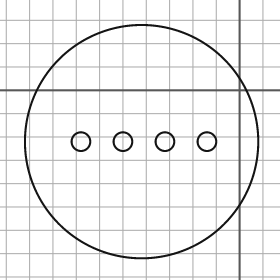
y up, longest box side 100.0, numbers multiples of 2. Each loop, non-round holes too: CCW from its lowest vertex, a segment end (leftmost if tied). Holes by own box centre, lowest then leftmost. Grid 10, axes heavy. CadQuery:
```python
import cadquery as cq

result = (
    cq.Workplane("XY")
    .moveTo(-42.0, -22.0)
    .circle(50.0)
    .moveTo(-68.0, -22.0)
    .circle(4.0)
    .moveTo(-50.0, -22.0)
    .circle(4.0)
    .moveTo(-32.0, -22.0)
    .circle(4.0)
    .moveTo(-14.0, -22.0)
    .circle(4.0)
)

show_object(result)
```